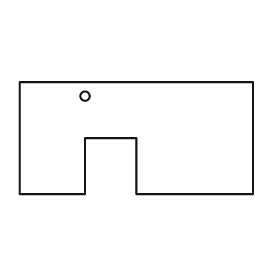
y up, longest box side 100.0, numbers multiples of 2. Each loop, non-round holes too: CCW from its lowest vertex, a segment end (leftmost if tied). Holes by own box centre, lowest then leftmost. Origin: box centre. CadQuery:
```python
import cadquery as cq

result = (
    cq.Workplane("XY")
    .moveTo(-50.0, -24.0)
    .lineTo(-22.0, -24.0)
    .lineTo(-22.0, 0.0)
    .lineTo(0.0, 0.0)
    .lineTo(0.0, -24.0)
    .lineTo(50.0, -24.0)
    .lineTo(50.0, 24.0)
    .lineTo(-50.0, 24.0)
    .close()
    .moveTo(-22.0, 18.0)
    .circle(2.0)
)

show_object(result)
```